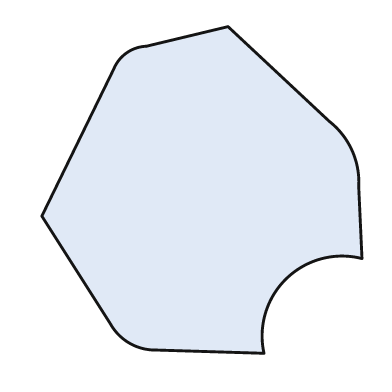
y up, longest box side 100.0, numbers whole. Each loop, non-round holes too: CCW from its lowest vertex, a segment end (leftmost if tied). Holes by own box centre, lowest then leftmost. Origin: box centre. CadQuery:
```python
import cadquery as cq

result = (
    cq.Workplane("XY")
    .moveTo(19.0, -50.0)
    .threePointArc((26.0, -27.0), (49.0, -21.0))
    .lineTo(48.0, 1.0)
    .threePointArc((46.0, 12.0), (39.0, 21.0))
    .lineTo(8.0, 50.0)
    .lineTo(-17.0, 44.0)
    .threePointArc((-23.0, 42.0), (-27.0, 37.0))
    .lineTo(-49.0, -8.0)
    .lineTo(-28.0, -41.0)
    .threePointArc((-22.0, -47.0), (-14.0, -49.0))
    .close()
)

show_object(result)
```